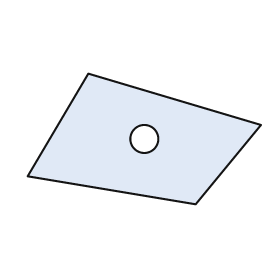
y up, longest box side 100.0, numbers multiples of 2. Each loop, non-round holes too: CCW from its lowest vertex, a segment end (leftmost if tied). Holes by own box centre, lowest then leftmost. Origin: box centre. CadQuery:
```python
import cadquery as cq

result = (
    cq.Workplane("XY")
    .moveTo(22.0, -28.0)
    .lineTo(50.0, 6.0)
    .lineTo(-24.0, 28.0)
    .lineTo(-50.0, -16.0)
    .close()
    .moveTo(0.0, 0.0)
    .circle(6.0)
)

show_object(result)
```